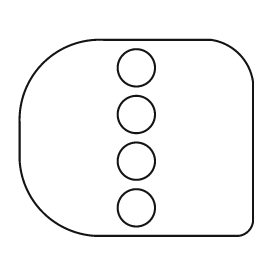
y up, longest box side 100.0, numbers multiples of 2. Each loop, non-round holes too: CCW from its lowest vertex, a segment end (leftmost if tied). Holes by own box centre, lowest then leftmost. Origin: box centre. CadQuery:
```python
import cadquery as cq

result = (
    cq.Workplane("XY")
    .moveTo(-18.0, -42.0)
    .lineTo(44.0, -42.0)
    .threePointArc((48.0, -40.0), (50.0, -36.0))
    .lineTo(50.0, 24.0)
    .threePointArc((44.0, 36.0), (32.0, 42.0))
    .lineTo(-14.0, 42.0)
    .threePointArc((-40.0, 32.0), (-50.0, 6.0))
    .lineTo(-50.0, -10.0)
    .threePointArc((-40.0, -32.0), (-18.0, -42.0))
    .close()
    .moveTo(0.0, -30.0)
    .circle(8.0)
    .moveTo(0.0, -10.0)
    .circle(8.0)
    .moveTo(0.0, 10.0)
    .circle(8.0)
    .moveTo(0.0, 30.0)
    .circle(8.0)
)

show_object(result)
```